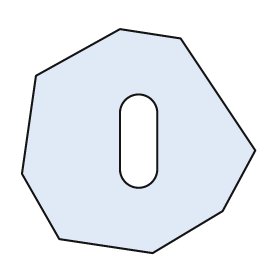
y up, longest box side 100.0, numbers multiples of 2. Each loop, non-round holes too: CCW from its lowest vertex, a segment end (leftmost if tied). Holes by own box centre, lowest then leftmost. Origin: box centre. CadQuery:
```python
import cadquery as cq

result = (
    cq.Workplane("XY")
    .moveTo(6.0, -48.0)
    .lineTo(36.0, -30.0)
    .lineTo(50.0, -4.0)
    .lineTo(18.0, 44.0)
    .lineTo(-8.0, 48.0)
    .lineTo(-44.0, 28.0)
    .lineTo(-50.0, -14.0)
    .lineTo(-34.0, -42.0)
    .close()
    .moveTo(-8.0, -12.0)
    .threePointArc((0.0, -20.0), (8.0, -12.0))
    .lineTo(8.0, 12.0)
    .threePointArc((0.0, 20.0), (-8.0, 12.0))
    .close()
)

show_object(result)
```